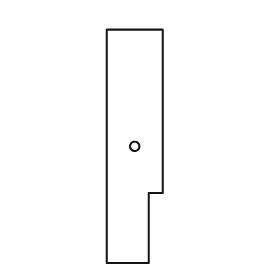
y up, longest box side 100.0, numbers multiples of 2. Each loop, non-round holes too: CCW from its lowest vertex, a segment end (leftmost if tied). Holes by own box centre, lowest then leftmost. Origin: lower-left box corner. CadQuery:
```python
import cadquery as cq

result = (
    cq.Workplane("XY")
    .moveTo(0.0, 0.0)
    .lineTo(18.0, 0.0)
    .lineTo(18.0, 30.0)
    .lineTo(24.0, 30.0)
    .lineTo(24.0, 100.0)
    .lineTo(0.0, 100.0)
    .close()
    .moveTo(12.0, 50.0)
    .circle(2.0)
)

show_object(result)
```